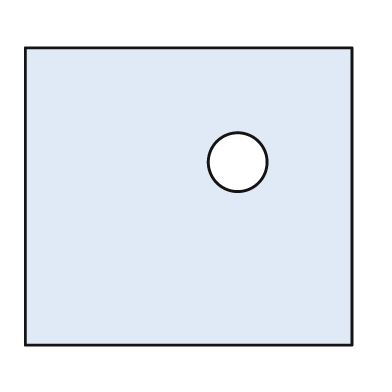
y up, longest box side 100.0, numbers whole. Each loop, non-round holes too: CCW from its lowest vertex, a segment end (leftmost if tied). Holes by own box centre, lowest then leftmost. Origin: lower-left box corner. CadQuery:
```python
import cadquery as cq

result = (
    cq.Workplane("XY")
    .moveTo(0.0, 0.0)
    .lineTo(100.0, 0.0)
    .lineTo(100.0, 91.0)
    .lineTo(0.0, 91.0)
    .close()
    .moveTo(65.0, 56.0)
    .circle(9.0)
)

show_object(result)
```